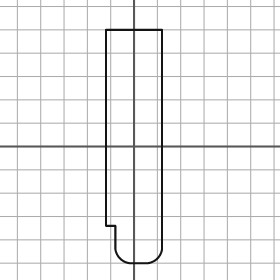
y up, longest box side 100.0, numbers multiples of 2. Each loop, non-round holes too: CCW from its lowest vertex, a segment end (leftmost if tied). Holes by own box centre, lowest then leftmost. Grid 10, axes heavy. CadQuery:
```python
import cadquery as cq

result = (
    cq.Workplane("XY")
    .moveTo(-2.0, -50.0)
    .lineTo(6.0, -50.0)
    .threePointArc((10.0, -48.0), (12.0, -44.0))
    .lineTo(12.0, 50.0)
    .lineTo(-12.0, 50.0)
    .lineTo(-12.0, -34.0)
    .lineTo(-8.0, -34.0)
    .lineTo(-8.0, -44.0)
    .threePointArc((-6.0, -48.0), (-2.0, -50.0))
    .close()
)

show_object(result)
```